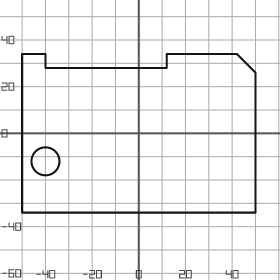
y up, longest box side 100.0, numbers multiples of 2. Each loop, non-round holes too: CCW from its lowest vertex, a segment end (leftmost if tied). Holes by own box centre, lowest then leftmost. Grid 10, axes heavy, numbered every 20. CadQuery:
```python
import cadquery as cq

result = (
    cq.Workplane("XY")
    .moveTo(-50.0, -34.0)
    .lineTo(50.0, -34.0)
    .lineTo(50.0, 26.0)
    .lineTo(42.0, 34.0)
    .lineTo(12.0, 34.0)
    .lineTo(12.0, 28.0)
    .lineTo(-40.0, 28.0)
    .lineTo(-40.0, 34.0)
    .lineTo(-50.0, 34.0)
    .close()
    .moveTo(-40.0, -12.0)
    .circle(6.0)
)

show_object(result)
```